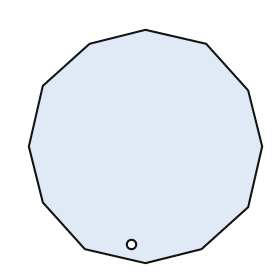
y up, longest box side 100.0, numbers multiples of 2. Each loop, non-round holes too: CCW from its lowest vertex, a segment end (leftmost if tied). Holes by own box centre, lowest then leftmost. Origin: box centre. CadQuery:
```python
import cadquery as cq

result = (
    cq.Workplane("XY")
    .moveTo(0.0, -50.0)
    .lineTo(24.0, -44.0)
    .lineTo(44.0, -26.0)
    .lineTo(50.0, 0.0)
    .lineTo(44.0, 24.0)
    .lineTo(26.0, 44.0)
    .lineTo(0.0, 50.0)
    .lineTo(-24.0, 44.0)
    .lineTo(-44.0, 26.0)
    .lineTo(-50.0, 0.0)
    .lineTo(-44.0, -24.0)
    .lineTo(-26.0, -44.0)
    .close()
    .moveTo(-6.0, -42.0)
    .circle(2.0)
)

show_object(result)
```